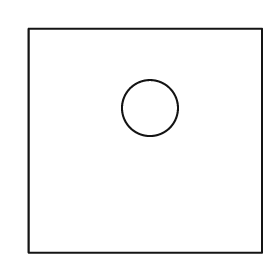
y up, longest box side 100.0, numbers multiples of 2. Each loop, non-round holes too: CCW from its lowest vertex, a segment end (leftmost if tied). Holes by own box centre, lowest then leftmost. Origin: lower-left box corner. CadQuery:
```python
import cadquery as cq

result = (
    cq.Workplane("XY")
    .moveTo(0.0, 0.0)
    .lineTo(100.0, 0.0)
    .lineTo(100.0, 96.0)
    .lineTo(0.0, 96.0)
    .close()
    .moveTo(52.0, 62.0)
    .circle(12.0)
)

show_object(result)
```